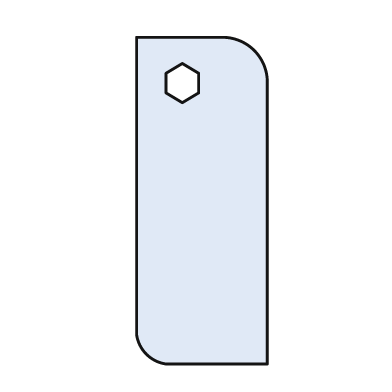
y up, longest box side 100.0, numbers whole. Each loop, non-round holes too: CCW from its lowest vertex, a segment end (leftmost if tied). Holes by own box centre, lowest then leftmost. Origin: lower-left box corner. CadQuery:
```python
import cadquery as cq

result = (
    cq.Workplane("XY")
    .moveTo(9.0, 0.0)
    .lineTo(40.0, 0.0)
    .lineTo(40.0, 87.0)
    .threePointArc((36.0, 96.0), (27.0, 100.0))
    .lineTo(0.0, 100.0)
    .lineTo(0.0, 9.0)
    .threePointArc((3.0, 3.0), (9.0, 0.0))
    .close()
    .moveTo(14.0, 80.0)
    .lineTo(19.0, 83.0)
    .lineTo(19.0, 89.0)
    .lineTo(14.0, 92.0)
    .lineTo(9.0, 89.0)
    .lineTo(9.0, 83.0)
    .close()
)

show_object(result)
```